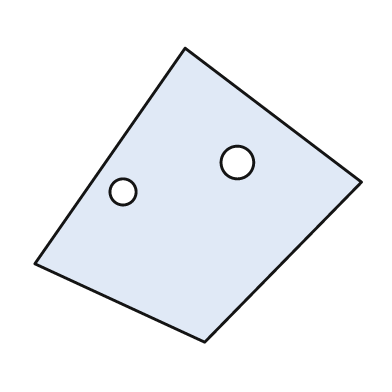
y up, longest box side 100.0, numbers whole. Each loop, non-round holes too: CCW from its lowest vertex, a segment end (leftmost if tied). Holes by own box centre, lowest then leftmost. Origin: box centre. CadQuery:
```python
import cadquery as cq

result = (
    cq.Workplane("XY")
    .moveTo(2.0, -45.0)
    .lineTo(50.0, 4.0)
    .lineTo(-4.0, 45.0)
    .lineTo(-50.0, -21.0)
    .close()
    .moveTo(-23.0, 1.0)
    .circle(4.0)
    .moveTo(12.0, 10.0)
    .circle(5.0)
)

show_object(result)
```